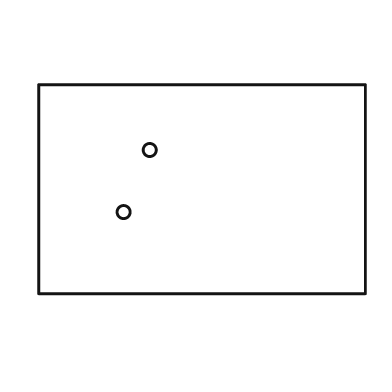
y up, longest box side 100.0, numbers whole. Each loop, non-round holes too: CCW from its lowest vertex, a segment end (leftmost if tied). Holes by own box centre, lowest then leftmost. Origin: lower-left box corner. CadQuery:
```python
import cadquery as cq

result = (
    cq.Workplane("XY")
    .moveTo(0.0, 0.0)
    .lineTo(100.0, 0.0)
    .lineTo(100.0, 64.0)
    .lineTo(0.0, 64.0)
    .close()
    .moveTo(26.0, 25.0)
    .circle(2.0)
    .moveTo(34.0, 44.0)
    .circle(2.0)
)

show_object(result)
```